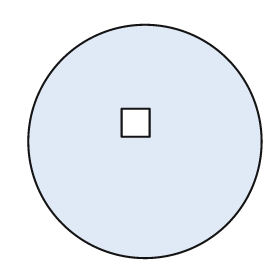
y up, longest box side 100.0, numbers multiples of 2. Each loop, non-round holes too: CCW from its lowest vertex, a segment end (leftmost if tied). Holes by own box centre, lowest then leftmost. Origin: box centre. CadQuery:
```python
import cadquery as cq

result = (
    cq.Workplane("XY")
    .moveTo(0.0, 0.0)
    .circle(50.0)
    .moveTo(-10.0, 2.0)
    .lineTo(2.0, 2.0)
    .lineTo(2.0, 14.0)
    .lineTo(-10.0, 14.0)
    .close()
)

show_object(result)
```